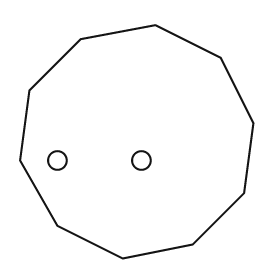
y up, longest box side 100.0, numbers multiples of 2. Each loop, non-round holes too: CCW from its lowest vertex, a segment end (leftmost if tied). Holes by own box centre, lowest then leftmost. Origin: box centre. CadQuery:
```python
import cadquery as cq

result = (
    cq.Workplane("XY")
    .moveTo(-6.0, -50.0)
    .lineTo(24.0, -44.0)
    .lineTo(46.0, -22.0)
    .lineTo(50.0, 8.0)
    .lineTo(36.0, 36.0)
    .lineTo(8.0, 50.0)
    .lineTo(-24.0, 44.0)
    .lineTo(-46.0, 22.0)
    .lineTo(-50.0, -8.0)
    .lineTo(-34.0, -36.0)
    .close()
    .moveTo(-34.0, -8.0)
    .circle(4.0)
    .moveTo(2.0, -8.0)
    .circle(4.0)
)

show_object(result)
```